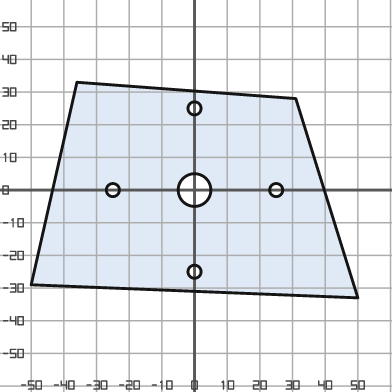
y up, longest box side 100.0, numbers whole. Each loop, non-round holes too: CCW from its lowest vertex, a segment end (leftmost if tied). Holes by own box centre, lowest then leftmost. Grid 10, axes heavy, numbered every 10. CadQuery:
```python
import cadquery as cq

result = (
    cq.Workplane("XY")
    .moveTo(50.0, -33.0)
    .lineTo(31.0, 28.0)
    .lineTo(-36.0, 33.0)
    .lineTo(-50.0, -29.0)
    .close()
    .moveTo(0.0, -25.0)
    .circle(2.0)
    .moveTo(-25.0, 0.0)
    .circle(2.0)
    .moveTo(0.0, 0.0)
    .circle(5.0)
    .moveTo(25.0, 0.0)
    .circle(2.0)
    .moveTo(0.0, 25.0)
    .circle(2.0)
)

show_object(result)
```